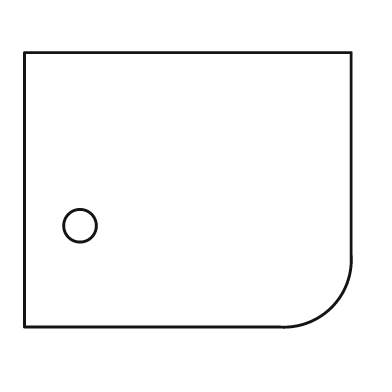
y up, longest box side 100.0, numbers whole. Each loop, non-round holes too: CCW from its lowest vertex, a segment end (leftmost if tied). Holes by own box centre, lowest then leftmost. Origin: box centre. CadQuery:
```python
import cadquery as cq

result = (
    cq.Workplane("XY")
    .moveTo(-50.0, -42.0)
    .lineTo(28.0, -42.0)
    .threePointArc((44.0, -36.0), (50.0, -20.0))
    .lineTo(50.0, 42.0)
    .lineTo(-50.0, 42.0)
    .close()
    .moveTo(-33.0, -11.0)
    .circle(5.0)
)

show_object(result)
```